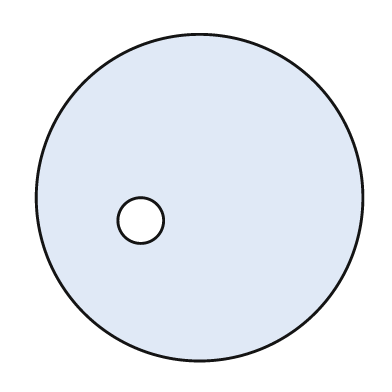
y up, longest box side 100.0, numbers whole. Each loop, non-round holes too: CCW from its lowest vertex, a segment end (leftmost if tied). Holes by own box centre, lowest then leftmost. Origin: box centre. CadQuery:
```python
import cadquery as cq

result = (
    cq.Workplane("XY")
    .moveTo(0.0, 0.0)
    .circle(50.0)
    .moveTo(-18.0, -7.0)
    .circle(7.0)
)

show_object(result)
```